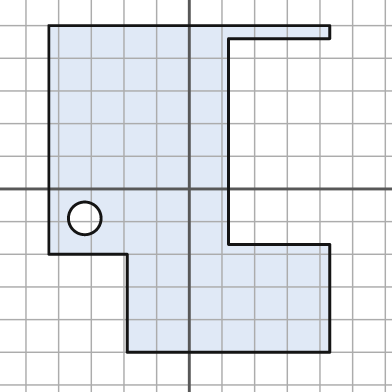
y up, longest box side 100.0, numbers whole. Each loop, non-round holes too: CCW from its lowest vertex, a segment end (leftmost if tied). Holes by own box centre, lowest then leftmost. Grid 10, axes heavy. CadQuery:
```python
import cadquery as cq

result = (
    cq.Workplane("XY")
    .moveTo(-19.0, -50.0)
    .lineTo(43.0, -50.0)
    .lineTo(43.0, -17.0)
    .lineTo(12.0, -17.0)
    .lineTo(12.0, 46.0)
    .lineTo(43.0, 46.0)
    .lineTo(43.0, 50.0)
    .lineTo(-43.0, 50.0)
    .lineTo(-43.0, -20.0)
    .lineTo(-19.0, -20.0)
    .close()
    .moveTo(-32.0, -9.0)
    .circle(5.0)
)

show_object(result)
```